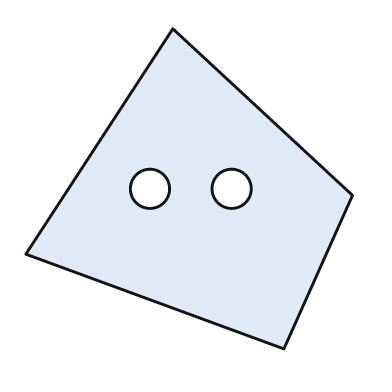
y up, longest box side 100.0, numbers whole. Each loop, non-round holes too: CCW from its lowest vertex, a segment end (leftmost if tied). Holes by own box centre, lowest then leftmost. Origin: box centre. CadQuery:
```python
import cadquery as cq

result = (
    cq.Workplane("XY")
    .moveTo(29.0, -49.0)
    .lineTo(50.0, -2.0)
    .lineTo(-5.0, 49.0)
    .lineTo(-50.0, -20.0)
    .close()
    .moveTo(-12.0, 0.0)
    .circle(6.0)
    .moveTo(13.0, 0.0)
    .circle(6.0)
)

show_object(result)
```